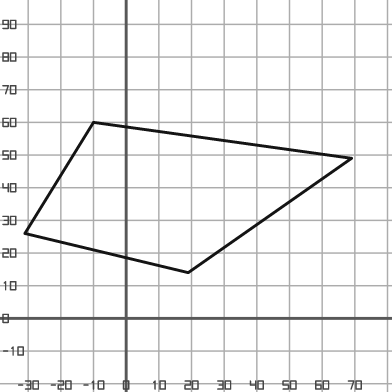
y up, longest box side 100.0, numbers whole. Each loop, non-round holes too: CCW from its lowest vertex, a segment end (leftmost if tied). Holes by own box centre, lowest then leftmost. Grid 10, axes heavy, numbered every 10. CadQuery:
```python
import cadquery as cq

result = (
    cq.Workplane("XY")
    .moveTo(19.0, 14.0)
    .lineTo(69.0, 49.0)
    .lineTo(-10.0, 60.0)
    .lineTo(-31.0, 26.0)
    .close()
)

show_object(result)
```